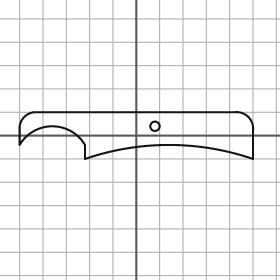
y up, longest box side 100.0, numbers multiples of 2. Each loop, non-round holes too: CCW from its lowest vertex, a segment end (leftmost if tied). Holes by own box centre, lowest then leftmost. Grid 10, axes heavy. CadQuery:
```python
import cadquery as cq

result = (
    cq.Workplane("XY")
    .moveTo(-22.0, -10.0)
    .threePointArc((14.0, -4.0), (50.0, -10.0))
    .lineTo(50.0, 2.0)
    .threePointArc((48.0, 8.0), (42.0, 10.0))
    .lineTo(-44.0, 10.0)
    .threePointArc((-48.0, 8.0), (-50.0, 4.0))
    .lineTo(-50.0, -4.0)
    .threePointArc((-36.0, 4.0), (-22.0, -4.0))
    .close()
    .moveTo(8.0, 4.0)
    .circle(2.0)
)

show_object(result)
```